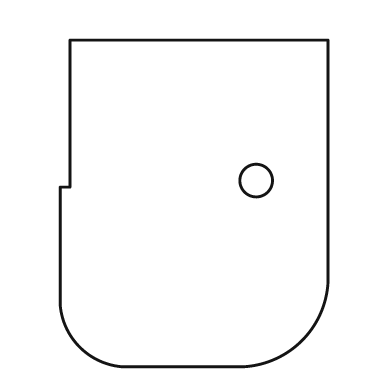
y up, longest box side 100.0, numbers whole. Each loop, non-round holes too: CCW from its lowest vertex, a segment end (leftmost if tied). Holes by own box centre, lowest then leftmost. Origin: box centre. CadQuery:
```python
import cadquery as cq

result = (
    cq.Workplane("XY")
    .moveTo(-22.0, -50.0)
    .lineTo(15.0, -50.0)
    .threePointArc((33.0, -42.0), (41.0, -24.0))
    .lineTo(41.0, 50.0)
    .lineTo(-38.0, 50.0)
    .lineTo(-38.0, 5.0)
    .lineTo(-41.0, 5.0)
    .lineTo(-41.0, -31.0)
    .threePointArc((-35.0, -44.0), (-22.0, -50.0))
    .close()
    .moveTo(19.0, 7.0)
    .circle(5.0)
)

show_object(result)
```